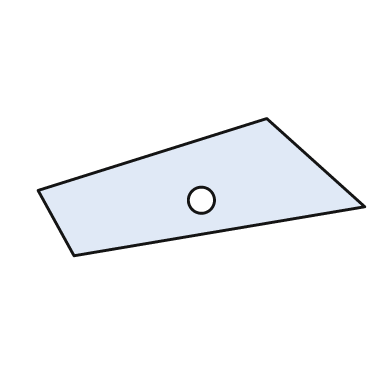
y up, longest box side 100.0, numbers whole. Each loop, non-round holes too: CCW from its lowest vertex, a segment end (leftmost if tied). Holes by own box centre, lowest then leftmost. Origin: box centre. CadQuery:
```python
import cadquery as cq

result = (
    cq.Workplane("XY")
    .moveTo(-39.0, -21.0)
    .lineTo(50.0, -6.0)
    .lineTo(20.0, 21.0)
    .lineTo(-50.0, -1.0)
    .close()
    .moveTo(0.0, -4.0)
    .circle(4.0)
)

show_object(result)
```